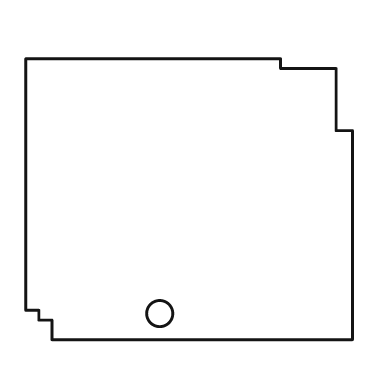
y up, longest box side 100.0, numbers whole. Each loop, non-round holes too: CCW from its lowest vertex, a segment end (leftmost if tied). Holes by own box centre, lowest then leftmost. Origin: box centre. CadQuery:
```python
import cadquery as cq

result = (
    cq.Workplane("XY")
    .moveTo(-42.0, -43.0)
    .lineTo(50.0, -43.0)
    .lineTo(50.0, 21.0)
    .lineTo(45.0, 21.0)
    .lineTo(45.0, 40.0)
    .lineTo(28.0, 40.0)
    .lineTo(28.0, 43.0)
    .lineTo(-50.0, 43.0)
    .lineTo(-50.0, -34.0)
    .lineTo(-46.0, -34.0)
    .lineTo(-46.0, -37.0)
    .lineTo(-42.0, -37.0)
    .close()
    .moveTo(-9.0, -35.0)
    .circle(4.0)
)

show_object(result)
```